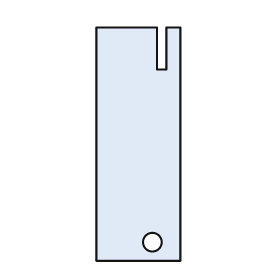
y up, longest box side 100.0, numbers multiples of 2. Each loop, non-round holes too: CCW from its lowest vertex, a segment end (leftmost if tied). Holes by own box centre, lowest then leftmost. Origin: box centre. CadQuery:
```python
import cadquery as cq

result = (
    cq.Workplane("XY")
    .moveTo(-18.0, -50.0)
    .lineTo(18.0, -50.0)
    .lineTo(18.0, 50.0)
    .lineTo(12.0, 50.0)
    .lineTo(12.0, 32.0)
    .lineTo(8.0, 32.0)
    .lineTo(8.0, 50.0)
    .lineTo(-18.0, 50.0)
    .close()
    .moveTo(6.0, -42.0)
    .circle(4.0)
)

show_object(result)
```